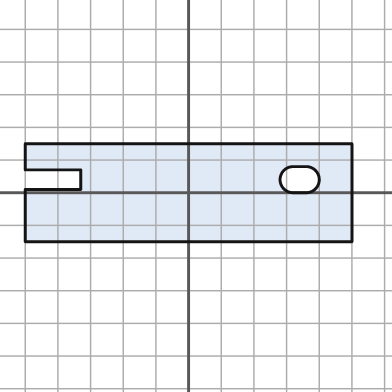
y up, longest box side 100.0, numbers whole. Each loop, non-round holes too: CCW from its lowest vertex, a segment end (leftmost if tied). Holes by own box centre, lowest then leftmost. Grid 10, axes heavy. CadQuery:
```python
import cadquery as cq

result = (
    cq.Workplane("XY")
    .moveTo(-50.0, -15.0)
    .lineTo(50.0, -15.0)
    .lineTo(50.0, 15.0)
    .lineTo(-50.0, 15.0)
    .lineTo(-50.0, 7.0)
    .lineTo(-33.0, 7.0)
    .lineTo(-33.0, 1.0)
    .lineTo(-50.0, 1.0)
    .close()
    .moveTo(32.0, 0.0)
    .lineTo(36.0, 0.0)
    .threePointArc((40.0, 4.0), (36.0, 8.0))
    .lineTo(32.0, 8.0)
    .threePointArc((28.0, 4.0), (32.0, 0.0))
    .close()
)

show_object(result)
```